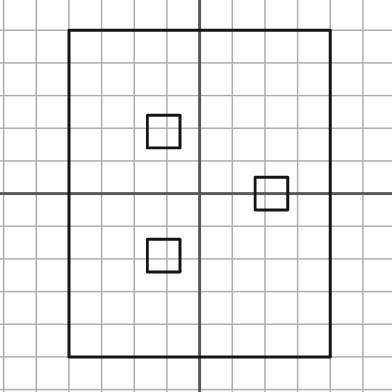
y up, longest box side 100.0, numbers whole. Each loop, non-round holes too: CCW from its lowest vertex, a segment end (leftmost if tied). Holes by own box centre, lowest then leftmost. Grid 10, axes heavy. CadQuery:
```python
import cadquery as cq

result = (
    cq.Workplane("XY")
    .moveTo(-40.0, -50.0)
    .lineTo(40.0, -50.0)
    .lineTo(40.0, 50.0)
    .lineTo(-40.0, 50.0)
    .close()
    .moveTo(-16.0, -24.0)
    .lineTo(-6.0, -24.0)
    .lineTo(-6.0, -14.0)
    .lineTo(-16.0, -14.0)
    .close()
    .moveTo(17.0, -5.0)
    .lineTo(27.0, -5.0)
    .lineTo(27.0, 5.0)
    .lineTo(17.0, 5.0)
    .close()
    .moveTo(-16.0, 14.0)
    .lineTo(-6.0, 14.0)
    .lineTo(-6.0, 24.0)
    .lineTo(-16.0, 24.0)
    .close()
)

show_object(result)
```